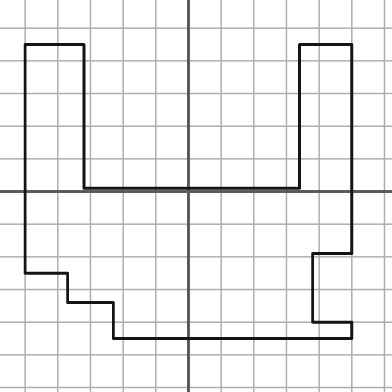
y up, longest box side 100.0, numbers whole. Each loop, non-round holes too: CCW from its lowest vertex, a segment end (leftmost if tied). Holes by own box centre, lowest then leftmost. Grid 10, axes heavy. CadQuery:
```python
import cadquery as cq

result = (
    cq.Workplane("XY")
    .moveTo(-23.0, -45.0)
    .lineTo(50.0, -45.0)
    .lineTo(50.0, -40.0)
    .lineTo(38.0, -40.0)
    .lineTo(38.0, -19.0)
    .lineTo(50.0, -19.0)
    .lineTo(50.0, 45.0)
    .lineTo(34.0, 45.0)
    .lineTo(34.0, 1.0)
    .lineTo(-32.0, 1.0)
    .lineTo(-32.0, 45.0)
    .lineTo(-50.0, 45.0)
    .lineTo(-50.0, -25.0)
    .lineTo(-37.0, -25.0)
    .lineTo(-37.0, -34.0)
    .lineTo(-23.0, -34.0)
    .close()
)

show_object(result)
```